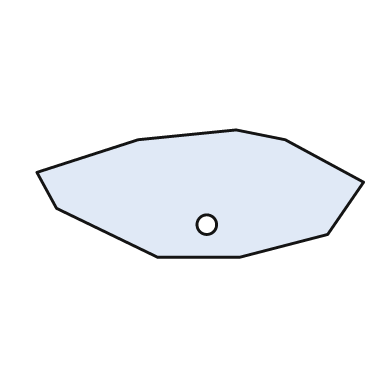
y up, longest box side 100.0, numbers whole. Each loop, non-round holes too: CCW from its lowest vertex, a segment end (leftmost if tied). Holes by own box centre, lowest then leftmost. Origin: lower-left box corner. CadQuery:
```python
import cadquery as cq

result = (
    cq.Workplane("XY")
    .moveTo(37.0, 0.0)
    .lineTo(62.0, 0.0)
    .lineTo(89.0, 7.0)
    .lineTo(100.0, 23.0)
    .lineTo(76.0, 36.0)
    .lineTo(61.0, 39.0)
    .lineTo(31.0, 36.0)
    .lineTo(0.0, 26.0)
    .lineTo(6.0, 15.0)
    .close()
    .moveTo(52.0, 10.0)
    .circle(3.0)
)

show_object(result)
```